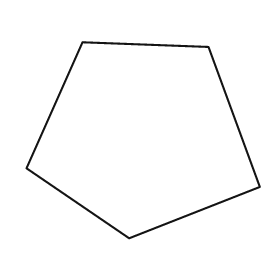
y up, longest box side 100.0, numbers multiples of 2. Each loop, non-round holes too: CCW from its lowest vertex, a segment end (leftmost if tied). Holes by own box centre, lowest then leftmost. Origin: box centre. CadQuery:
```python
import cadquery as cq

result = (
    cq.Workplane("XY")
    .moveTo(-6.0, -42.0)
    .lineTo(50.0, -20.0)
    .lineTo(28.0, 40.0)
    .lineTo(-26.0, 42.0)
    .lineTo(-50.0, -12.0)
    .close()
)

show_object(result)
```